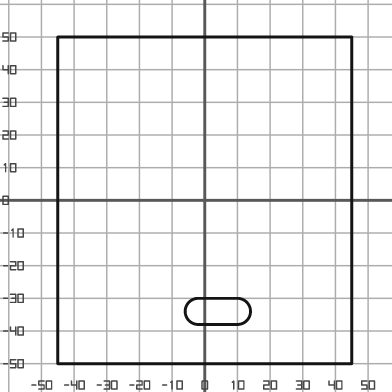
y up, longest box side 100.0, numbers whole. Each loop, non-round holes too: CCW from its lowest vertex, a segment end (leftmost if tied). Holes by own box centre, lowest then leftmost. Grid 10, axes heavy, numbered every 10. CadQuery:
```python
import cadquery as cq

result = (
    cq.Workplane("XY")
    .moveTo(-45.0, -50.0)
    .lineTo(45.0, -50.0)
    .lineTo(45.0, 50.0)
    .lineTo(-45.0, 50.0)
    .close()
    .moveTo(-2.0, -38.0)
    .lineTo(10.0, -38.0)
    .threePointArc((14.0, -34.0), (10.0, -30.0))
    .lineTo(-2.0, -30.0)
    .threePointArc((-6.0, -34.0), (-2.0, -38.0))
    .close()
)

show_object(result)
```